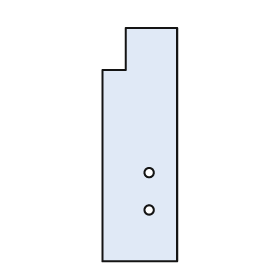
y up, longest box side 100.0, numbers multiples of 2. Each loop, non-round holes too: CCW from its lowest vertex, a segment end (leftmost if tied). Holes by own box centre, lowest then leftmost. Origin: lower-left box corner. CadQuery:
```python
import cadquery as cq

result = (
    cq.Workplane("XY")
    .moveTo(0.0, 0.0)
    .lineTo(32.0, 0.0)
    .lineTo(32.0, 100.0)
    .lineTo(10.0, 100.0)
    .lineTo(10.0, 82.0)
    .lineTo(0.0, 82.0)
    .close()
    .moveTo(20.0, 22.0)
    .circle(2.0)
    .moveTo(20.0, 38.0)
    .circle(2.0)
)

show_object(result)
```